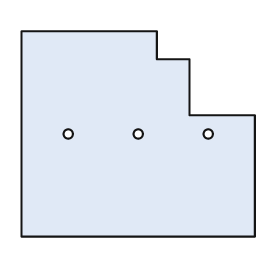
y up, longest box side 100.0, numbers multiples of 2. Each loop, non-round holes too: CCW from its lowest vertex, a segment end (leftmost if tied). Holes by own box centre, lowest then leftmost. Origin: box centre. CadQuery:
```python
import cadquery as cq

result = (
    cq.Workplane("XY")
    .moveTo(-50.0, -44.0)
    .lineTo(50.0, -44.0)
    .lineTo(50.0, 8.0)
    .lineTo(22.0, 8.0)
    .lineTo(22.0, 32.0)
    .lineTo(8.0, 32.0)
    .lineTo(8.0, 44.0)
    .lineTo(-50.0, 44.0)
    .close()
    .moveTo(-30.0, 0.0)
    .circle(2.0)
    .moveTo(0.0, 0.0)
    .circle(2.0)
    .moveTo(30.0, 0.0)
    .circle(2.0)
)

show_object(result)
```